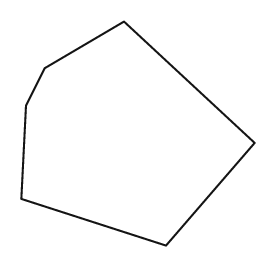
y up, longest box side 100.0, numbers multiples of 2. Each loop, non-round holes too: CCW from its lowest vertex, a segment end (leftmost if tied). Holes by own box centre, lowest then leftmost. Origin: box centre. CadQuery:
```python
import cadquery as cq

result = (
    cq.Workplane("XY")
    .moveTo(12.0, -48.0)
    .lineTo(50.0, -4.0)
    .lineTo(-6.0, 48.0)
    .lineTo(-40.0, 28.0)
    .lineTo(-48.0, 12.0)
    .lineTo(-50.0, -28.0)
    .close()
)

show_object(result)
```